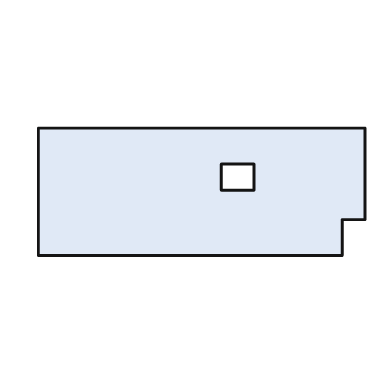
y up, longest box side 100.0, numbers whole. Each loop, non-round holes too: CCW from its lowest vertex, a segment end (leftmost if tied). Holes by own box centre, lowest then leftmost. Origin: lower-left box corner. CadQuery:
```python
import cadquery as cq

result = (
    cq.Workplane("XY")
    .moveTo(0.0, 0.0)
    .lineTo(93.0, 0.0)
    .lineTo(93.0, 11.0)
    .lineTo(100.0, 11.0)
    .lineTo(100.0, 39.0)
    .lineTo(0.0, 39.0)
    .close()
    .moveTo(56.0, 20.0)
    .lineTo(66.0, 20.0)
    .lineTo(66.0, 28.0)
    .lineTo(56.0, 28.0)
    .close()
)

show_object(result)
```